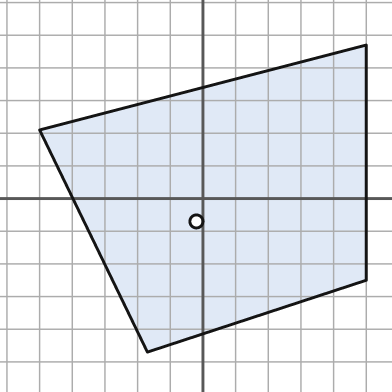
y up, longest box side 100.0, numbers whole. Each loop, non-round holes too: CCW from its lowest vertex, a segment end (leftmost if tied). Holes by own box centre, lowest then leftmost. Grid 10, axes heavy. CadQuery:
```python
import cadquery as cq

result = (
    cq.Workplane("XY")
    .moveTo(-17.0, -47.0)
    .lineTo(50.0, -25.0)
    .lineTo(50.0, 47.0)
    .lineTo(-50.0, 21.0)
    .close()
    .moveTo(-2.0, -7.0)
    .circle(2.0)
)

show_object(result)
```